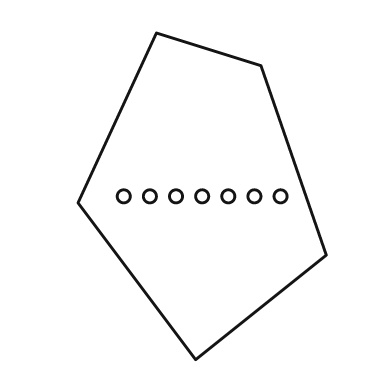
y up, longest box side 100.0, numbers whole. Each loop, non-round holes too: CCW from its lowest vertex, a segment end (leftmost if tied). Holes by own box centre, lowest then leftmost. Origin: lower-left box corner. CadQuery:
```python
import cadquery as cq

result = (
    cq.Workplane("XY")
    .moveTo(36.0, 0.0)
    .lineTo(76.0, 32.0)
    .lineTo(56.0, 90.0)
    .lineTo(24.0, 100.0)
    .lineTo(0.0, 48.0)
    .close()
    .moveTo(14.0, 50.0)
    .circle(2.0)
    .moveTo(22.0, 50.0)
    .circle(2.0)
    .moveTo(30.0, 50.0)
    .circle(2.0)
    .moveTo(38.0, 50.0)
    .circle(2.0)
    .moveTo(46.0, 50.0)
    .circle(2.0)
    .moveTo(54.0, 50.0)
    .circle(2.0)
    .moveTo(62.0, 50.0)
    .circle(2.0)
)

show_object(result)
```